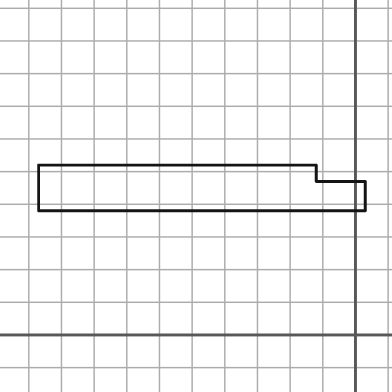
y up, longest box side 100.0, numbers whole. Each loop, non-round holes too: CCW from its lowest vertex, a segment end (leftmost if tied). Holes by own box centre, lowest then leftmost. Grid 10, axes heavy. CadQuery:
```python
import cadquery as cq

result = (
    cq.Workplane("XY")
    .moveTo(-97.0, 38.0)
    .lineTo(3.0, 38.0)
    .lineTo(3.0, 47.0)
    .lineTo(-12.0, 47.0)
    .lineTo(-12.0, 52.0)
    .lineTo(-97.0, 52.0)
    .close()
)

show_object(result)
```